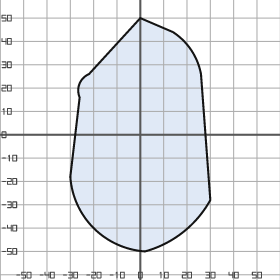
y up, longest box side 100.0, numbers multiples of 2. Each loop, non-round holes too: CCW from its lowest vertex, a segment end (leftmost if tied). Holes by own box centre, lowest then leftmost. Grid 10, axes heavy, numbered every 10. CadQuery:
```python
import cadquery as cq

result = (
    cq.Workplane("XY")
    .moveTo(2.0, -50.0)
    .threePointArc((18.0, -42.0), (30.0, -28.0))
    .lineTo(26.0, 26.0)
    .threePointArc((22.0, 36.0), (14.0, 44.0))
    .lineTo(0.0, 50.0)
    .lineTo(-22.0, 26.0)
    .threePointArc((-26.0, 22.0), (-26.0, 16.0))
    .lineTo(-30.0, -18.0)
    .threePointArc((-20.0, -40.0), (2.0, -50.0))
    .close()
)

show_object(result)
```